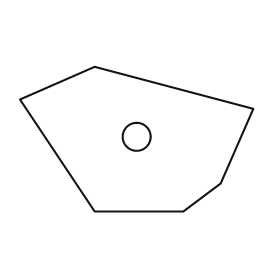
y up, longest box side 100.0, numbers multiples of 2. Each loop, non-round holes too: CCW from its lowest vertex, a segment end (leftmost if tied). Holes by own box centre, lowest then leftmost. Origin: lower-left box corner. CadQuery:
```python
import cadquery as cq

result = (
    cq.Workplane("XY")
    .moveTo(32.0, 0.0)
    .lineTo(70.0, 0.0)
    .lineTo(86.0, 12.0)
    .lineTo(100.0, 44.0)
    .lineTo(32.0, 62.0)
    .lineTo(0.0, 48.0)
    .close()
    .moveTo(50.0, 32.0)
    .circle(6.0)
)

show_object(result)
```